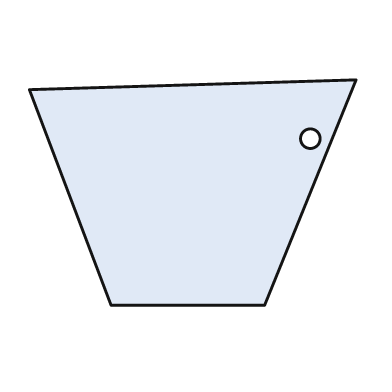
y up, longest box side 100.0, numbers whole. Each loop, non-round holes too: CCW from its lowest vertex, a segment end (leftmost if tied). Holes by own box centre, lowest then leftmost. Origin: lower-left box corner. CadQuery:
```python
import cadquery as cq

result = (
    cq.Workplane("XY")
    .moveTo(25.0, 0.0)
    .lineTo(72.0, 0.0)
    .lineTo(100.0, 69.0)
    .lineTo(0.0, 66.0)
    .close()
    .moveTo(86.0, 51.0)
    .circle(3.0)
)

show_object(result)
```